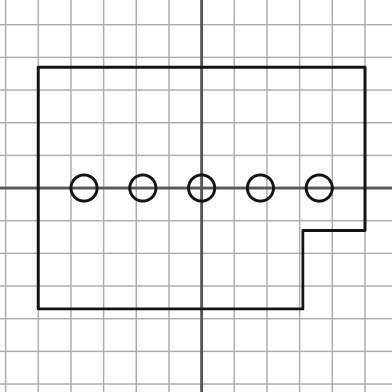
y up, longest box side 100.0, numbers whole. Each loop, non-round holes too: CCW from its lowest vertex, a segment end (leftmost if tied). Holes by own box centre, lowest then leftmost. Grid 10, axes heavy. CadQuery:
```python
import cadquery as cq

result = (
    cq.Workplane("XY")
    .moveTo(-50.0, -37.0)
    .lineTo(31.0, -37.0)
    .lineTo(31.0, -13.0)
    .lineTo(50.0, -13.0)
    .lineTo(50.0, 37.0)
    .lineTo(-50.0, 37.0)
    .close()
    .moveTo(-36.0, 0.0)
    .circle(4.0)
    .moveTo(-18.0, 0.0)
    .circle(4.0)
    .moveTo(0.0, 0.0)
    .circle(4.0)
    .moveTo(18.0, 0.0)
    .circle(4.0)
    .moveTo(36.0, 0.0)
    .circle(4.0)
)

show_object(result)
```